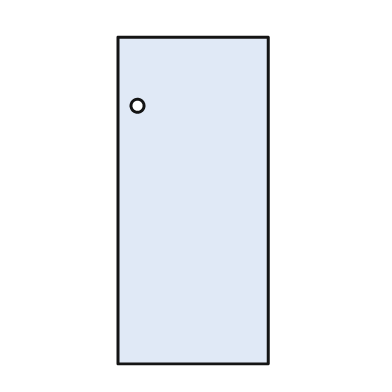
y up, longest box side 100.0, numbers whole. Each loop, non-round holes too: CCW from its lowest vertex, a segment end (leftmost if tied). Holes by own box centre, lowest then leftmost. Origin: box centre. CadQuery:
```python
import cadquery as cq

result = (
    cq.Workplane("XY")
    .moveTo(-23.0, -50.0)
    .lineTo(23.0, -50.0)
    .lineTo(23.0, 50.0)
    .lineTo(-23.0, 50.0)
    .close()
    .moveTo(-17.0, 29.0)
    .circle(2.0)
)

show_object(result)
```